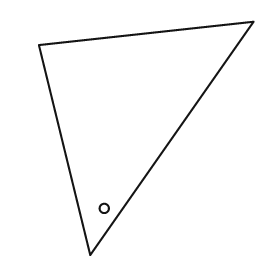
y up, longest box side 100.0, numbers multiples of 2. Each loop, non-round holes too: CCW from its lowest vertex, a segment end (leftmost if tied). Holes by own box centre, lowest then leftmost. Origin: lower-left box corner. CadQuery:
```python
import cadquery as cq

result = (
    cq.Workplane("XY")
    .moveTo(22.0, 0.0)
    .lineTo(92.0, 100.0)
    .lineTo(0.0, 90.0)
    .close()
    .moveTo(28.0, 20.0)
    .circle(2.0)
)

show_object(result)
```